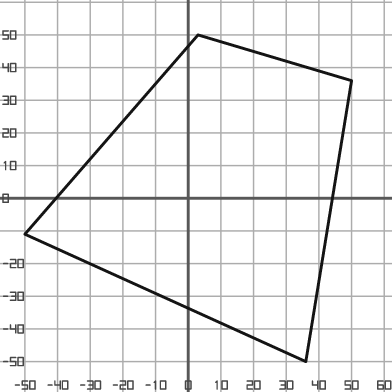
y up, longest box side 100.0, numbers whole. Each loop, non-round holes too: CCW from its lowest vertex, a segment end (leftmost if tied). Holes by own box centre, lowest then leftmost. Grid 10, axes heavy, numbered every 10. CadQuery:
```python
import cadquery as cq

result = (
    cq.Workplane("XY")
    .moveTo(36.0, -50.0)
    .lineTo(50.0, 36.0)
    .lineTo(3.0, 50.0)
    .lineTo(-50.0, -11.0)
    .close()
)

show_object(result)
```